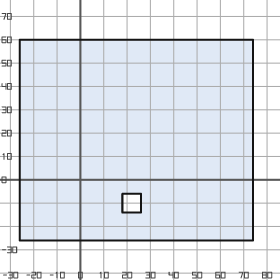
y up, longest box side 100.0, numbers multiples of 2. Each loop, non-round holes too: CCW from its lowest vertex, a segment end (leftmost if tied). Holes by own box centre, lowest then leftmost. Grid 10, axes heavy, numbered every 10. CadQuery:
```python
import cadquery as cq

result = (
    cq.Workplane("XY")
    .moveTo(-26.0, -26.0)
    .lineTo(74.0, -26.0)
    .lineTo(74.0, 60.0)
    .lineTo(-26.0, 60.0)
    .close()
    .moveTo(18.0, -14.0)
    .lineTo(26.0, -14.0)
    .lineTo(26.0, -6.0)
    .lineTo(18.0, -6.0)
    .close()
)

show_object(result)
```